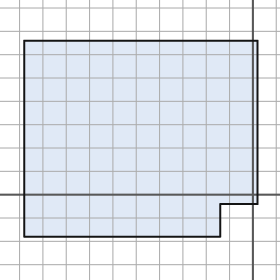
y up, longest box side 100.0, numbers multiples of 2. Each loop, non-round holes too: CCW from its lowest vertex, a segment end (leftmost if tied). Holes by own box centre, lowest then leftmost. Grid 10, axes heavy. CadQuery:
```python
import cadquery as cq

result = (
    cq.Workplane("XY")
    .moveTo(-98.0, -18.0)
    .lineTo(-14.0, -18.0)
    .lineTo(-14.0, -4.0)
    .lineTo(2.0, -4.0)
    .lineTo(2.0, 66.0)
    .lineTo(-98.0, 66.0)
    .close()
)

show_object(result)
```